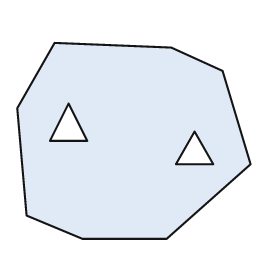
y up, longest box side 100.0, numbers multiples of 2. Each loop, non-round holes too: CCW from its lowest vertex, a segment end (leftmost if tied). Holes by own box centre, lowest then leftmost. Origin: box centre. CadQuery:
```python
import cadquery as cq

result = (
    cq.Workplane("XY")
    .moveTo(-22.0, -42.0)
    .lineTo(14.0, -42.0)
    .lineTo(50.0, -10.0)
    .lineTo(38.0, 30.0)
    .lineTo(16.0, 40.0)
    .lineTo(-34.0, 42.0)
    .lineTo(-50.0, 14.0)
    .lineTo(-46.0, -32.0)
    .close()
    .moveTo(18.0, -10.0)
    .lineTo(34.0, -10.0)
    .lineTo(26.0, 4.0)
    .close()
    .moveTo(-36.0, 0.0)
    .lineTo(-20.0, 0.0)
    .lineTo(-28.0, 16.0)
    .close()
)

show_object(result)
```